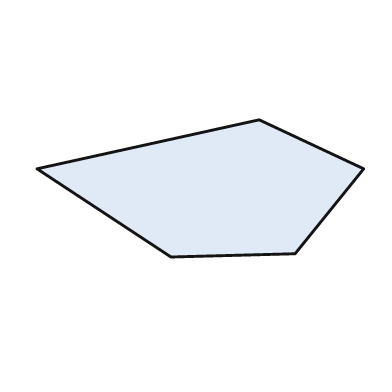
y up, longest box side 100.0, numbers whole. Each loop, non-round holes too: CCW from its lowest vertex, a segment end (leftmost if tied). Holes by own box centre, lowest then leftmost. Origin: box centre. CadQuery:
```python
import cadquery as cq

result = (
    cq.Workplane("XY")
    .moveTo(-9.0, -21.0)
    .lineTo(29.0, -20.0)
    .lineTo(50.0, 6.0)
    .lineTo(18.0, 21.0)
    .lineTo(-50.0, 6.0)
    .close()
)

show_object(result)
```